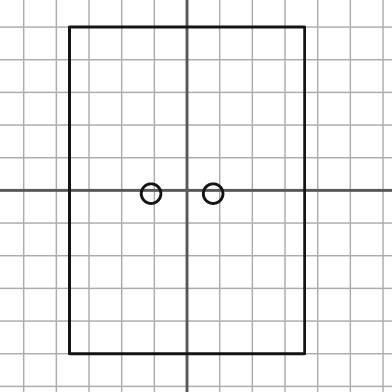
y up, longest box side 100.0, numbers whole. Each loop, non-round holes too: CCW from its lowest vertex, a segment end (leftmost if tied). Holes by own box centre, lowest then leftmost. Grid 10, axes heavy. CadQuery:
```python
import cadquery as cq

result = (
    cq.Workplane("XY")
    .moveTo(-36.0, -50.0)
    .lineTo(36.0, -50.0)
    .lineTo(36.0, 50.0)
    .lineTo(-36.0, 50.0)
    .close()
    .moveTo(-11.0, -1.0)
    .circle(3.0)
    .moveTo(8.0, -1.0)
    .circle(3.0)
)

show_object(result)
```